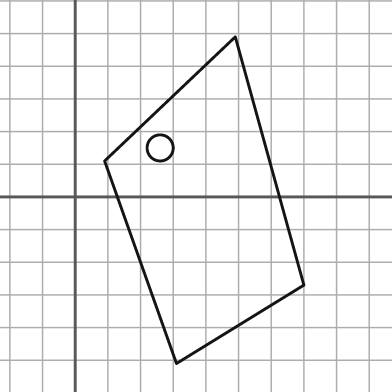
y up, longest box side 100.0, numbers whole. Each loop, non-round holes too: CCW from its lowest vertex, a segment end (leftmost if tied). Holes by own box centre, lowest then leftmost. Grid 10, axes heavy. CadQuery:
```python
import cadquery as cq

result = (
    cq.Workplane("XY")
    .moveTo(31.0, -51.0)
    .lineTo(70.0, -27.0)
    .lineTo(49.0, 49.0)
    .lineTo(9.0, 11.0)
    .close()
    .moveTo(26.0, 15.0)
    .circle(4.0)
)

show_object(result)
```